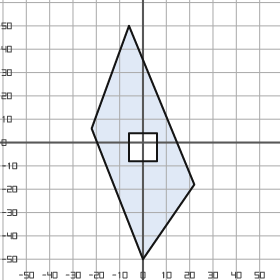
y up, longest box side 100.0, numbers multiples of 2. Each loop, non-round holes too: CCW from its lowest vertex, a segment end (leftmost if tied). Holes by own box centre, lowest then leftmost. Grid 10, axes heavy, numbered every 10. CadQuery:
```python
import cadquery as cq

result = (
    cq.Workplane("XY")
    .moveTo(0.0, -50.0)
    .lineTo(22.0, -18.0)
    .lineTo(-6.0, 50.0)
    .lineTo(-22.0, 6.0)
    .close()
    .moveTo(-6.0, -8.0)
    .lineTo(6.0, -8.0)
    .lineTo(6.0, 4.0)
    .lineTo(-6.0, 4.0)
    .close()
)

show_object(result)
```